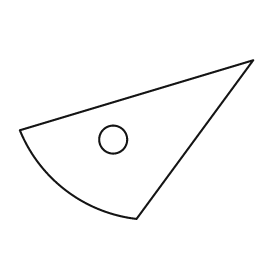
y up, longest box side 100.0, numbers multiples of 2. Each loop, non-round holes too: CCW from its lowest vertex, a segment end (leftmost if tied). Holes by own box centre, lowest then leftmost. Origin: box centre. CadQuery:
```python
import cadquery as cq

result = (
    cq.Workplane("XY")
    .moveTo(0.0, -34.0)
    .lineTo(50.0, 34.0)
    .lineTo(-50.0, 4.0)
    .threePointArc((-30.0, -22.0), (0.0, -34.0))
    .close()
    .moveTo(-10.0, 0.0)
    .circle(6.0)
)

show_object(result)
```